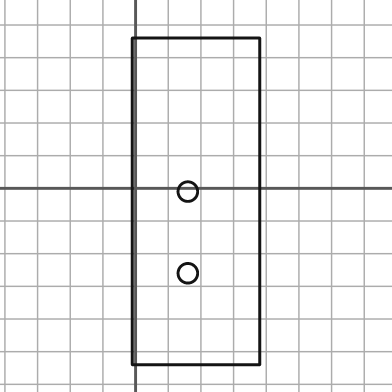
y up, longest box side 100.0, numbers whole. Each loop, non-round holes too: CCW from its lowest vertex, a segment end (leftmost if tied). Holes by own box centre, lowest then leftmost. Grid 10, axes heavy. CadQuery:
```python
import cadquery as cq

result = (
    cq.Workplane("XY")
    .moveTo(-1.0, -54.0)
    .lineTo(38.0, -54.0)
    .lineTo(38.0, 46.0)
    .lineTo(-1.0, 46.0)
    .close()
    .moveTo(16.0, -26.0)
    .circle(3.0)
    .moveTo(16.0, -1.0)
    .circle(3.0)
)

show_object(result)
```